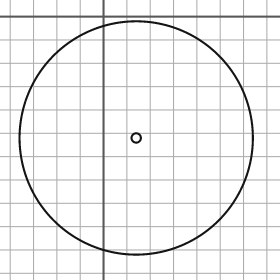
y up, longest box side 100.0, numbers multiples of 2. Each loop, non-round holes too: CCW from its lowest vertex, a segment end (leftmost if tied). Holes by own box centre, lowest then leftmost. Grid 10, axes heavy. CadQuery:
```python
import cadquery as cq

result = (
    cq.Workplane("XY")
    .moveTo(14.0, -52.0)
    .circle(50.0)
    .moveTo(14.0, -52.0)
    .circle(2.0)
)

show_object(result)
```